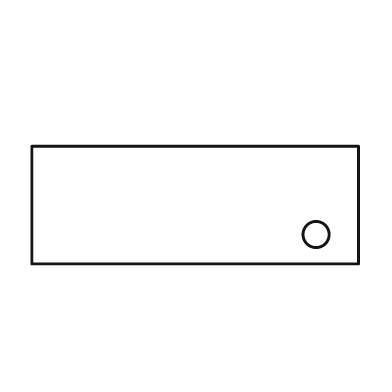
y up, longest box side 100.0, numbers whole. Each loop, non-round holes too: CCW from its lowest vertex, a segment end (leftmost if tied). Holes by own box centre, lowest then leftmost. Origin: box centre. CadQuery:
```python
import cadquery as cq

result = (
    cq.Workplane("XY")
    .moveTo(-50.0, -18.0)
    .lineTo(50.0, -18.0)
    .lineTo(50.0, 18.0)
    .lineTo(-50.0, 18.0)
    .close()
    .moveTo(37.0, -9.0)
    .circle(4.0)
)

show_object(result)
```